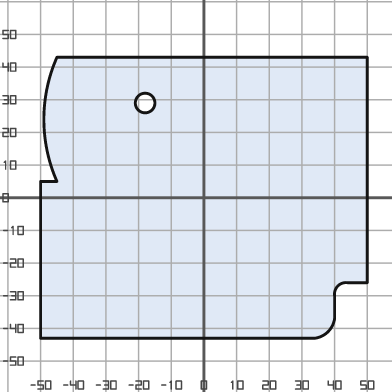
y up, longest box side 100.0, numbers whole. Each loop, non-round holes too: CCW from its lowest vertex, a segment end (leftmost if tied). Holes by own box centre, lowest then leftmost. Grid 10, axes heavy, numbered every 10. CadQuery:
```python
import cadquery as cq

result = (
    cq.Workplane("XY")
    .moveTo(-50.0, -43.0)
    .lineTo(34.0, -43.0)
    .threePointArc((38.0, -41.0), (40.0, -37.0))
    .lineTo(40.0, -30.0)
    .threePointArc((41.0, -27.0), (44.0, -26.0))
    .lineTo(50.0, -26.0)
    .lineTo(50.0, 43.0)
    .lineTo(-45.0, 43.0)
    .threePointArc((-49.0, 24.0), (-45.0, 5.0))
    .lineTo(-50.0, 5.0)
    .close()
    .moveTo(-18.0, 29.0)
    .circle(3.0)
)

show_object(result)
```